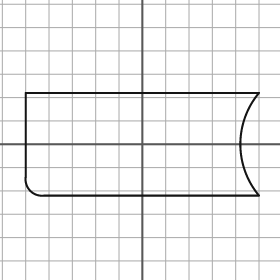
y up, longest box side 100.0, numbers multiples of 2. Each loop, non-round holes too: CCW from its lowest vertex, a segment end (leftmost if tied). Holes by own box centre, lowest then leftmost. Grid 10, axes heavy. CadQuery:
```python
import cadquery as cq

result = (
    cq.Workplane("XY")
    .moveTo(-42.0, -22.0)
    .lineTo(50.0, -22.0)
    .threePointArc((42.0, 0.0), (50.0, 22.0))
    .lineTo(-50.0, 22.0)
    .lineTo(-50.0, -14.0)
    .threePointArc((-48.0, -20.0), (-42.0, -22.0))
    .close()
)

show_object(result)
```